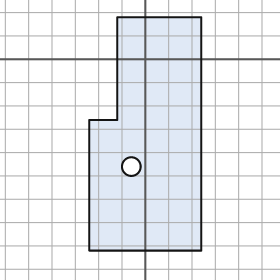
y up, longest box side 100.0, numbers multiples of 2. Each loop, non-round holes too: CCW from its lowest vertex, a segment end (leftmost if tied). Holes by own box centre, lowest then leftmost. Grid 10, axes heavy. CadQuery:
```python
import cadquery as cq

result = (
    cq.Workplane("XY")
    .moveTo(-24.0, -82.0)
    .lineTo(24.0, -82.0)
    .lineTo(24.0, 18.0)
    .lineTo(-12.0, 18.0)
    .lineTo(-12.0, -26.0)
    .lineTo(-24.0, -26.0)
    .close()
    .moveTo(-6.0, -46.0)
    .circle(4.0)
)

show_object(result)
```